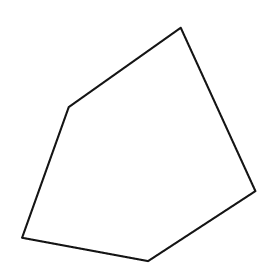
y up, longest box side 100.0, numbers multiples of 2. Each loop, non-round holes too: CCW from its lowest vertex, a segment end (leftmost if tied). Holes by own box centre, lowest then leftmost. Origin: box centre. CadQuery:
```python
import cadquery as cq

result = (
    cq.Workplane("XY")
    .moveTo(4.0, -50.0)
    .lineTo(50.0, -20.0)
    .lineTo(18.0, 50.0)
    .lineTo(-30.0, 16.0)
    .lineTo(-50.0, -40.0)
    .close()
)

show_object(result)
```